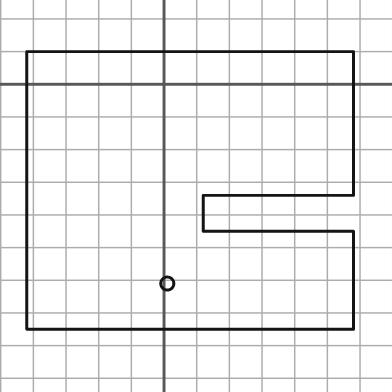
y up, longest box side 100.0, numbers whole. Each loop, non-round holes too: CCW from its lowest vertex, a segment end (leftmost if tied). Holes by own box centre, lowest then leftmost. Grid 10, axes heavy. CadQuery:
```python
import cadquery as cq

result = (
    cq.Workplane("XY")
    .moveTo(-42.0, -75.0)
    .lineTo(58.0, -75.0)
    .lineTo(58.0, -45.0)
    .lineTo(12.0, -45.0)
    .lineTo(12.0, -34.0)
    .lineTo(58.0, -34.0)
    .lineTo(58.0, 10.0)
    .lineTo(-42.0, 10.0)
    .close()
    .moveTo(1.0, -61.0)
    .circle(2.0)
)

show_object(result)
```